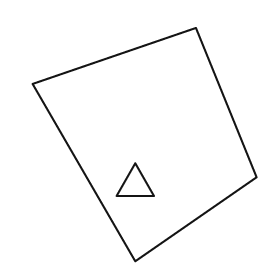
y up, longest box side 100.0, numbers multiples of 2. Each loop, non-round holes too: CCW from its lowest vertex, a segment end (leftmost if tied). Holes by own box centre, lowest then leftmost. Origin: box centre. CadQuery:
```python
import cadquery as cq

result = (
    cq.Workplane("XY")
    .moveTo(-4.0, -50.0)
    .lineTo(48.0, -14.0)
    .lineTo(22.0, 50.0)
    .lineTo(-48.0, 26.0)
    .close()
    .moveTo(-12.0, -22.0)
    .lineTo(4.0, -22.0)
    .lineTo(-4.0, -8.0)
    .close()
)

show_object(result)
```